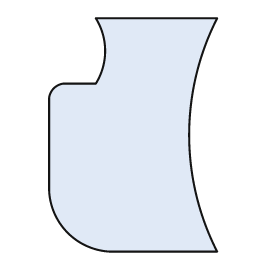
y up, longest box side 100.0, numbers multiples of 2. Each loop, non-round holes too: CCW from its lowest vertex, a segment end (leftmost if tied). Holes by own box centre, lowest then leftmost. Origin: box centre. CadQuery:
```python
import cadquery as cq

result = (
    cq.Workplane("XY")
    .moveTo(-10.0, -50.0)
    .lineTo(36.0, -50.0)
    .threePointArc((24.0, 0.0), (36.0, 50.0))
    .lineTo(-16.0, 50.0)
    .threePointArc((-12.0, 36.0), (-16.0, 22.0))
    .lineTo(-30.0, 22.0)
    .threePointArc((-34.0, 20.0), (-36.0, 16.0))
    .lineTo(-36.0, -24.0)
    .threePointArc((-28.0, -42.0), (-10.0, -50.0))
    .close()
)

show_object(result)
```